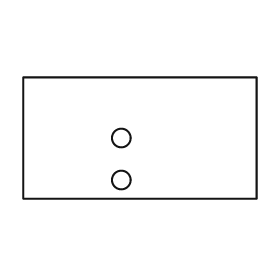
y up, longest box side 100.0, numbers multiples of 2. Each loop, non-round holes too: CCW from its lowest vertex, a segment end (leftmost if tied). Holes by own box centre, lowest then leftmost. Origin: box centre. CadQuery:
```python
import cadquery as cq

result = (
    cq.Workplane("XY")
    .moveTo(-50.0, -26.0)
    .lineTo(50.0, -26.0)
    .lineTo(50.0, 26.0)
    .lineTo(-50.0, 26.0)
    .close()
    .moveTo(-8.0, -18.0)
    .circle(4.0)
    .moveTo(-8.0, 0.0)
    .circle(4.0)
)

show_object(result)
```